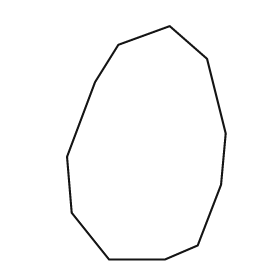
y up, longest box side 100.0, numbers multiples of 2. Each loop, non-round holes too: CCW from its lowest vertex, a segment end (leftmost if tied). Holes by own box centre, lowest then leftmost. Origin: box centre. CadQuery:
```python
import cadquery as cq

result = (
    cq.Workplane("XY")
    .moveTo(-16.0, -50.0)
    .lineTo(8.0, -50.0)
    .lineTo(22.0, -44.0)
    .lineTo(32.0, -18.0)
    .lineTo(34.0, 4.0)
    .lineTo(26.0, 36.0)
    .lineTo(10.0, 50.0)
    .lineTo(-12.0, 42.0)
    .lineTo(-22.0, 26.0)
    .lineTo(-34.0, -6.0)
    .lineTo(-32.0, -30.0)
    .close()
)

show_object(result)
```